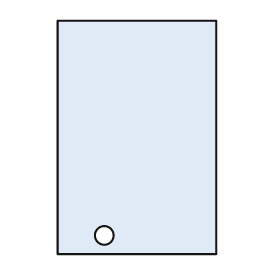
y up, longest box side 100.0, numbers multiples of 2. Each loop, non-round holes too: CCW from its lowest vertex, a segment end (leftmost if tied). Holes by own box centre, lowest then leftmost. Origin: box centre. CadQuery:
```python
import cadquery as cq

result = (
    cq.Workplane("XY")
    .moveTo(-34.0, -50.0)
    .lineTo(34.0, -50.0)
    .lineTo(34.0, 50.0)
    .lineTo(-34.0, 50.0)
    .close()
    .moveTo(-14.0, -42.0)
    .circle(4.0)
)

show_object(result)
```